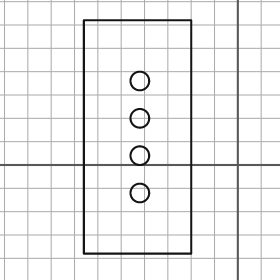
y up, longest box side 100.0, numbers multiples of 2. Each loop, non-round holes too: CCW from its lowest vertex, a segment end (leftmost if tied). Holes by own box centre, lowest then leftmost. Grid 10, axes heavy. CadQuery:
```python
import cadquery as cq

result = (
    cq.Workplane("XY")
    .moveTo(-66.0, -38.0)
    .lineTo(-20.0, -38.0)
    .lineTo(-20.0, 62.0)
    .lineTo(-66.0, 62.0)
    .close()
    .moveTo(-42.0, -12.0)
    .circle(4.0)
    .moveTo(-42.0, 4.0)
    .circle(4.0)
    .moveTo(-42.0, 20.0)
    .circle(4.0)
    .moveTo(-42.0, 36.0)
    .circle(4.0)
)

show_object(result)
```